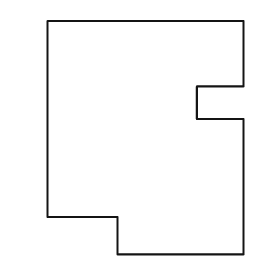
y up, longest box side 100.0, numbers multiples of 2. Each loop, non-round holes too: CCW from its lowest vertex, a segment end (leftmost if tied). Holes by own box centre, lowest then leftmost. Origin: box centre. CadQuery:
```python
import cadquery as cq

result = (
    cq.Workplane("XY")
    .moveTo(-12.0, -50.0)
    .lineTo(42.0, -50.0)
    .lineTo(42.0, 8.0)
    .lineTo(22.0, 8.0)
    .lineTo(22.0, 22.0)
    .lineTo(42.0, 22.0)
    .lineTo(42.0, 50.0)
    .lineTo(-42.0, 50.0)
    .lineTo(-42.0, -34.0)
    .lineTo(-12.0, -34.0)
    .close()
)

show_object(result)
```